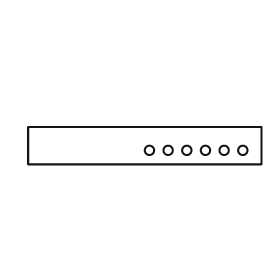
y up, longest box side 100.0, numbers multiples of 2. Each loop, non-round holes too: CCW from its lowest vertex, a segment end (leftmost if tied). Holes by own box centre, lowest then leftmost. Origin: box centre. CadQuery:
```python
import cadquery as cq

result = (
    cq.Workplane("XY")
    .moveTo(-50.0, -8.0)
    .lineTo(50.0, -8.0)
    .lineTo(50.0, 8.0)
    .lineTo(-50.0, 8.0)
    .close()
    .moveTo(2.0, -2.0)
    .circle(2.0)
    .moveTo(10.0, -2.0)
    .circle(2.0)
    .moveTo(18.0, -2.0)
    .circle(2.0)
    .moveTo(26.0, -2.0)
    .circle(2.0)
    .moveTo(34.0, -2.0)
    .circle(2.0)
    .moveTo(42.0, -2.0)
    .circle(2.0)
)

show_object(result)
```